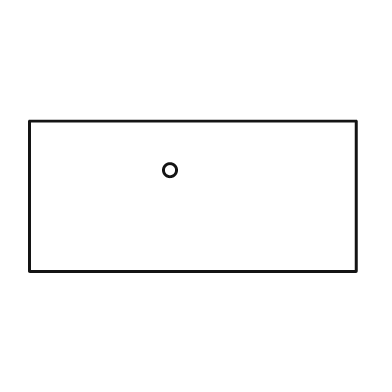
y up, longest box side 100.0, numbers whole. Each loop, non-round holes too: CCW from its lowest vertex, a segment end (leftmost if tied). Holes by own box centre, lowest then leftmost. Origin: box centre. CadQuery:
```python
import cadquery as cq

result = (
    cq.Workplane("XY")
    .moveTo(-50.0, -23.0)
    .lineTo(50.0, -23.0)
    .lineTo(50.0, 23.0)
    .lineTo(-50.0, 23.0)
    .close()
    .moveTo(-7.0, 8.0)
    .circle(2.0)
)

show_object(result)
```